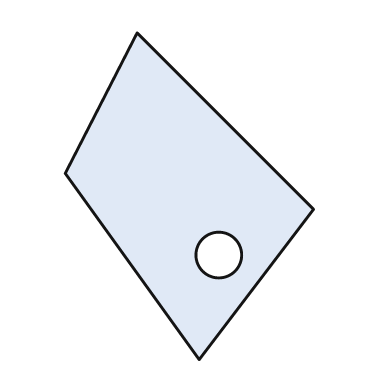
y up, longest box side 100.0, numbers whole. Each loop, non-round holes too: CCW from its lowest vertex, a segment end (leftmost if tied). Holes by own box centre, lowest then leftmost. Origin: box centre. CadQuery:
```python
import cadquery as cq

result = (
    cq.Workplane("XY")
    .moveTo(3.0, -50.0)
    .lineTo(38.0, -4.0)
    .lineTo(-16.0, 50.0)
    .lineTo(-38.0, 7.0)
    .close()
    .moveTo(9.0, -18.0)
    .circle(7.0)
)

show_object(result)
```